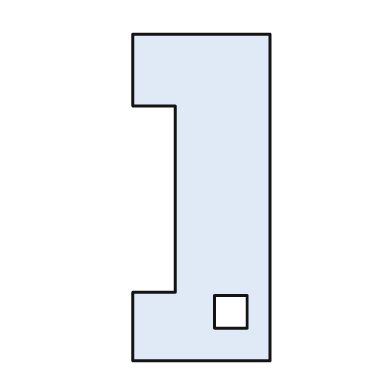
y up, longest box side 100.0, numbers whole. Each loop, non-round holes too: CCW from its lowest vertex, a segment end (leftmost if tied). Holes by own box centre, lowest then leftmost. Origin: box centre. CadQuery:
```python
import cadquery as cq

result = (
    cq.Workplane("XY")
    .moveTo(-21.0, -50.0)
    .lineTo(21.0, -50.0)
    .lineTo(21.0, 50.0)
    .lineTo(-21.0, 50.0)
    .lineTo(-21.0, 28.0)
    .lineTo(-8.0, 28.0)
    .lineTo(-8.0, -29.0)
    .lineTo(-21.0, -29.0)
    .close()
    .moveTo(4.0, -40.0)
    .lineTo(14.0, -40.0)
    .lineTo(14.0, -30.0)
    .lineTo(4.0, -30.0)
    .close()
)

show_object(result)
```